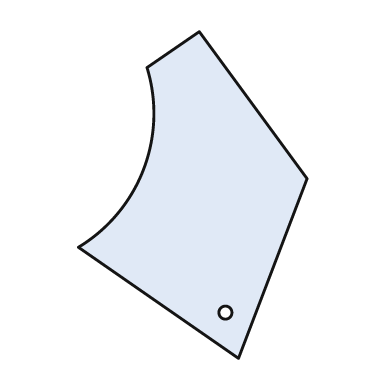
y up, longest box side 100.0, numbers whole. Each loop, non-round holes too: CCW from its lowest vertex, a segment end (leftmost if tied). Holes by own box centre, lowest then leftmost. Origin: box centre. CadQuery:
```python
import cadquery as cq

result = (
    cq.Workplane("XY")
    .moveTo(14.0, -50.0)
    .lineTo(35.0, 5.0)
    .lineTo(2.0, 50.0)
    .lineTo(-14.0, 39.0)
    .threePointArc((-15.0, 8.0), (-35.0, -16.0))
    .close()
    .moveTo(10.0, -36.0)
    .circle(2.0)
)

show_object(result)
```